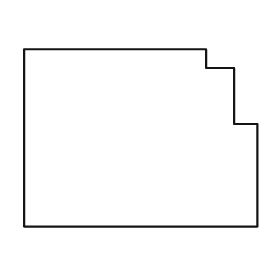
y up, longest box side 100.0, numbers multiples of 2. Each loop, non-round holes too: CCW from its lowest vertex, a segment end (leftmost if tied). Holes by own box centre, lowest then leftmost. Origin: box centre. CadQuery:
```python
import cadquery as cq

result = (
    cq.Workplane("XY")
    .moveTo(-50.0, -38.0)
    .lineTo(50.0, -38.0)
    .lineTo(50.0, 6.0)
    .lineTo(40.0, 6.0)
    .lineTo(40.0, 30.0)
    .lineTo(28.0, 30.0)
    .lineTo(28.0, 38.0)
    .lineTo(-50.0, 38.0)
    .close()
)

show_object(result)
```